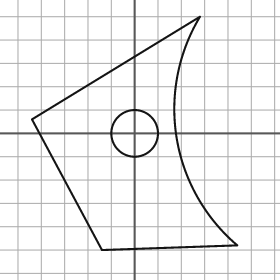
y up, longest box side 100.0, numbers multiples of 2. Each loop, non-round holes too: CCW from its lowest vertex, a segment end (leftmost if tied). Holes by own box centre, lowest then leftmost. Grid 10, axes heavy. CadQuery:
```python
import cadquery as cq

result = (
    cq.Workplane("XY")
    .moveTo(-14.0, -50.0)
    .lineTo(44.0, -48.0)
    .threePointArc((18.0, -2.0), (28.0, 50.0))
    .lineTo(-44.0, 6.0)
    .close()
    .moveTo(0.0, 0.0)
    .circle(10.0)
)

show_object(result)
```